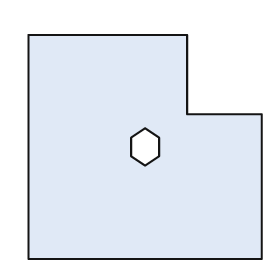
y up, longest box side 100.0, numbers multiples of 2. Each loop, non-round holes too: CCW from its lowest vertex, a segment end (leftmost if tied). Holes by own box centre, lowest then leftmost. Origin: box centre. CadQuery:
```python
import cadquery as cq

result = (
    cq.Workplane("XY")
    .moveTo(-50.0, -48.0)
    .lineTo(50.0, -48.0)
    .lineTo(50.0, 14.0)
    .lineTo(18.0, 14.0)
    .lineTo(18.0, 48.0)
    .lineTo(-50.0, 48.0)
    .close()
    .moveTo(0.0, -8.0)
    .lineTo(6.0, -4.0)
    .lineTo(6.0, 4.0)
    .lineTo(0.0, 8.0)
    .lineTo(-6.0, 4.0)
    .lineTo(-6.0, -4.0)
    .close()
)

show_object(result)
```